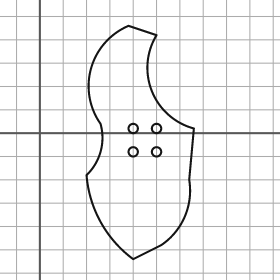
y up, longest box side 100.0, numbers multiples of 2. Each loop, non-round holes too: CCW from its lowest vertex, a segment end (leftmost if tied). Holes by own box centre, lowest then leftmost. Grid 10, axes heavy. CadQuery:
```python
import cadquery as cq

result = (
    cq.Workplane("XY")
    .moveTo(40.0, -54.0)
    .lineTo(52.0, -48.0)
    .threePointArc((62.0, -36.0), (64.0, -20.0))
    .lineTo(66.0, 2.0)
    .threePointArc((48.0, 18.0), (50.0, 42.0))
    .lineTo(38.0, 46.0)
    .threePointArc((22.0, 28.0), (26.0, 4.0))
    .threePointArc((26.0, -8.0), (20.0, -18.0))
    .threePointArc((26.0, -38.0), (40.0, -54.0))
    .close()
    .moveTo(40.0, -8.0)
    .circle(2.0)
    .moveTo(50.0, -8.0)
    .circle(2.0)
    .moveTo(40.0, 2.0)
    .circle(2.0)
    .moveTo(50.0, 2.0)
    .circle(2.0)
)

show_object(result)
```